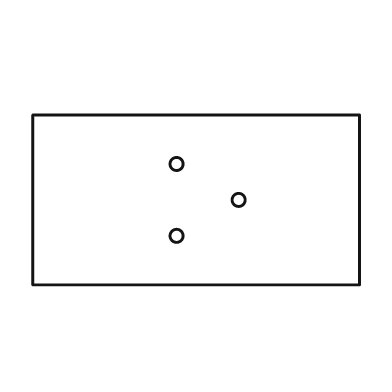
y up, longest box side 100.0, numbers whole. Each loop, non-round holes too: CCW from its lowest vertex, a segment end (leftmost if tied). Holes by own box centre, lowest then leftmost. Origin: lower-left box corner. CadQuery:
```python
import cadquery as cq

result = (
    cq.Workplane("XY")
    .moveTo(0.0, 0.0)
    .lineTo(100.0, 0.0)
    .lineTo(100.0, 52.0)
    .lineTo(0.0, 52.0)
    .close()
    .moveTo(44.0, 15.0)
    .circle(2.0)
    .moveTo(63.0, 26.0)
    .circle(2.0)
    .moveTo(44.0, 37.0)
    .circle(2.0)
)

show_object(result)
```